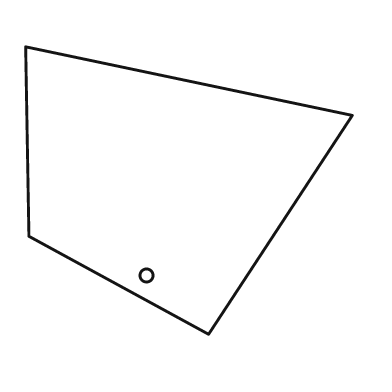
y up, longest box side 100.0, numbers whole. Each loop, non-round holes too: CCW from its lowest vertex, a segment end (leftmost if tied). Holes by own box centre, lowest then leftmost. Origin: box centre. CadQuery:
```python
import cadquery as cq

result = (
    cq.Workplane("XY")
    .moveTo(6.0, -44.0)
    .lineTo(50.0, 23.0)
    .lineTo(-50.0, 44.0)
    .lineTo(-49.0, -14.0)
    .close()
    .moveTo(-13.0, -26.0)
    .circle(2.0)
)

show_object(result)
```